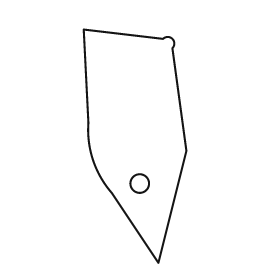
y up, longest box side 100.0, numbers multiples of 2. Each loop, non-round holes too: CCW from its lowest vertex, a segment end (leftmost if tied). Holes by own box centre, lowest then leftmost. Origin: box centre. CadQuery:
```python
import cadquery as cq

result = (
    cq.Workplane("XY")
    .moveTo(10.0, -50.0)
    .lineTo(22.0, -2.0)
    .lineTo(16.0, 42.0)
    .threePointArc((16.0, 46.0), (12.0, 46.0))
    .lineTo(-22.0, 50.0)
    .lineTo(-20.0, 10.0)
    .threePointArc((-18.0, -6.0), (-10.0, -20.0))
    .close()
    .moveTo(2.0, -16.0)
    .circle(4.0)
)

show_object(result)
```